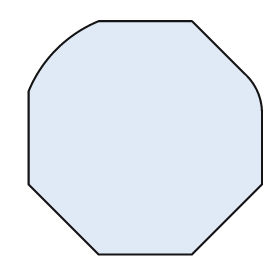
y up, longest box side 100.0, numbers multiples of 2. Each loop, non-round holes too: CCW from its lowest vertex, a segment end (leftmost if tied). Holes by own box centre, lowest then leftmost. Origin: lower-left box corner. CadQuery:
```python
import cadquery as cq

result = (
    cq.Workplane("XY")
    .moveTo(30.0, 0.0)
    .lineTo(70.0, 0.0)
    .lineTo(100.0, 30.0)
    .lineTo(100.0, 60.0)
    .threePointArc((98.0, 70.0), (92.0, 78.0))
    .lineTo(70.0, 100.0)
    .lineTo(30.0, 100.0)
    .threePointArc((12.0, 88.0), (0.0, 70.0))
    .lineTo(0.0, 30.0)
    .close()
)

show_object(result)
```